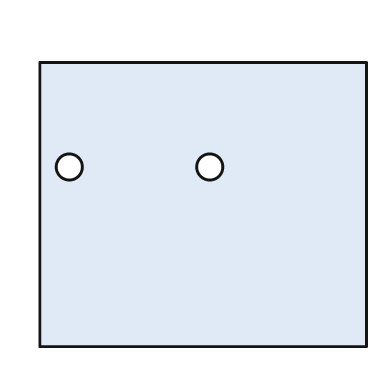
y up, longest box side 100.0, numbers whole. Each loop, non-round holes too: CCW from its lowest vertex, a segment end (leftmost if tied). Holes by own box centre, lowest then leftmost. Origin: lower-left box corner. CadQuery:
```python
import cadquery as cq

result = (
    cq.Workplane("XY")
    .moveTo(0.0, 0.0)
    .lineTo(100.0, 0.0)
    .lineTo(100.0, 87.0)
    .lineTo(0.0, 87.0)
    .close()
    .moveTo(9.0, 55.0)
    .circle(4.0)
    .moveTo(52.0, 55.0)
    .circle(4.0)
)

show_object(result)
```